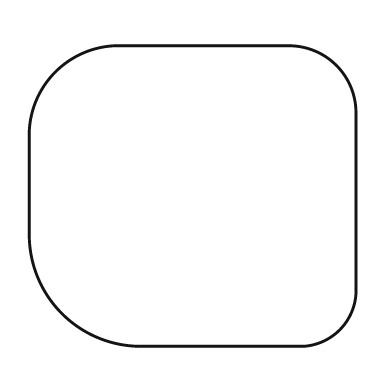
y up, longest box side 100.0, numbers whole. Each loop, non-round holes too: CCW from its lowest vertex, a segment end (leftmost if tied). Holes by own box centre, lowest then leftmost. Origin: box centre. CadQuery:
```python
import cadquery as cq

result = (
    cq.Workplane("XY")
    .moveTo(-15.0, -46.0)
    .lineTo(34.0, -46.0)
    .threePointArc((45.0, -41.0), (50.0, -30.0))
    .lineTo(50.0, 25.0)
    .threePointArc((44.0, 40.0), (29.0, 46.0))
    .lineTo(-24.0, 46.0)
    .threePointArc((-42.0, 38.0), (-50.0, 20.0))
    .lineTo(-50.0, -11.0)
    .threePointArc((-40.0, -36.0), (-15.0, -46.0))
    .close()
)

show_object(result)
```